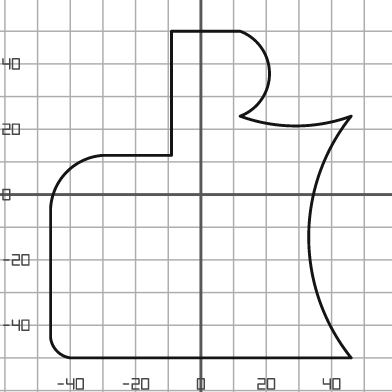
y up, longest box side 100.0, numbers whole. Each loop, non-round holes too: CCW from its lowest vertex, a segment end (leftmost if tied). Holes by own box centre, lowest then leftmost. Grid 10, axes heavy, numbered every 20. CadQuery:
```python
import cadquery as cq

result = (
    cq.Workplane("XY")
    .moveTo(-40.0, -50.0)
    .lineTo(46.0, -50.0)
    .threePointArc((33.0, -13.0), (46.0, 24.0))
    .threePointArc((29.0, 21.0), (12.0, 24.0))
    .threePointArc((21.0, 37.0), (12.0, 50.0))
    .lineTo(-9.0, 50.0)
    .lineTo(-9.0, 12.0)
    .lineTo(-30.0, 12.0)
    .threePointArc((-41.0, 7.0), (-46.0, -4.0))
    .lineTo(-46.0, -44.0)
    .threePointArc((-44.0, -48.0), (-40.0, -50.0))
    .close()
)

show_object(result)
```